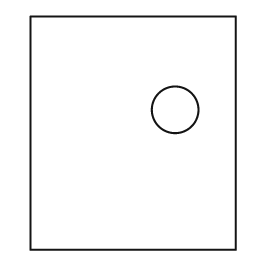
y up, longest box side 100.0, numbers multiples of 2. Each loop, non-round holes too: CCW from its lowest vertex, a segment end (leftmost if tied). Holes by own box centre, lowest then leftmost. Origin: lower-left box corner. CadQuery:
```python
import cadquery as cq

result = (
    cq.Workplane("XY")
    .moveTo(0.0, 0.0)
    .lineTo(88.0, 0.0)
    .lineTo(88.0, 100.0)
    .lineTo(0.0, 100.0)
    .close()
    .moveTo(62.0, 60.0)
    .circle(10.0)
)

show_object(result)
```